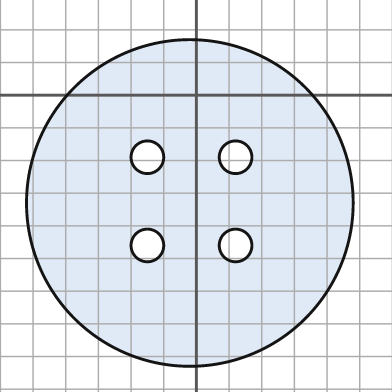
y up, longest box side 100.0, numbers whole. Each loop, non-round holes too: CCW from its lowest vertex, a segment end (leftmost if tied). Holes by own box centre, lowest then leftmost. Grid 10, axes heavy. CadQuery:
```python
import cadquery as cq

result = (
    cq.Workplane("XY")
    .moveTo(-2.0, -33.0)
    .circle(50.0)
    .moveTo(-15.0, -46.0)
    .circle(5.0)
    .moveTo(12.0, -46.0)
    .circle(5.0)
    .moveTo(-15.0, -19.0)
    .circle(5.0)
    .moveTo(12.0, -19.0)
    .circle(5.0)
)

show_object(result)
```